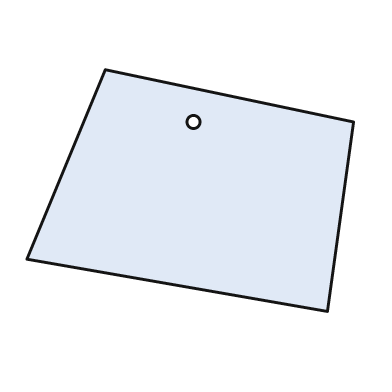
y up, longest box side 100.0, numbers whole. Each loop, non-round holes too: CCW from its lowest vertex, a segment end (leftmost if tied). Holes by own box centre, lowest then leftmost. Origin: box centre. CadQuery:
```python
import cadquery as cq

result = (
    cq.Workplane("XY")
    .moveTo(42.0, -37.0)
    .lineTo(50.0, 21.0)
    .lineTo(-26.0, 37.0)
    .lineTo(-50.0, -21.0)
    .close()
    .moveTo(1.0, 21.0)
    .circle(2.0)
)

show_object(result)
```